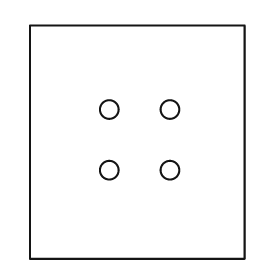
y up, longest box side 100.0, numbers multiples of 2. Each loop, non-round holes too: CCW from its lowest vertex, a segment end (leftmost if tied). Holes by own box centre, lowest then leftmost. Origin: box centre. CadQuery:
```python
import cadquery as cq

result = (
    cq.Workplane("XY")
    .moveTo(-46.0, -50.0)
    .lineTo(46.0, -50.0)
    .lineTo(46.0, 50.0)
    .lineTo(-46.0, 50.0)
    .close()
    .moveTo(-12.0, -12.0)
    .circle(4.0)
    .moveTo(14.0, -12.0)
    .circle(4.0)
    .moveTo(-12.0, 14.0)
    .circle(4.0)
    .moveTo(14.0, 14.0)
    .circle(4.0)
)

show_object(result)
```